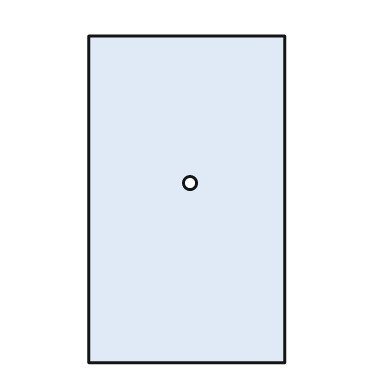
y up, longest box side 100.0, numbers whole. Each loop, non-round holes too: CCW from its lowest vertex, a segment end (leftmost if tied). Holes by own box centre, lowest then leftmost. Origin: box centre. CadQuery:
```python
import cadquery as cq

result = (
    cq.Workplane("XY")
    .moveTo(-30.0, -50.0)
    .lineTo(30.0, -50.0)
    .lineTo(30.0, 50.0)
    .lineTo(-30.0, 50.0)
    .close()
    .moveTo(1.0, 5.0)
    .circle(2.0)
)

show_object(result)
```